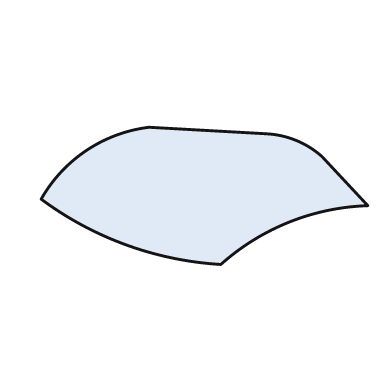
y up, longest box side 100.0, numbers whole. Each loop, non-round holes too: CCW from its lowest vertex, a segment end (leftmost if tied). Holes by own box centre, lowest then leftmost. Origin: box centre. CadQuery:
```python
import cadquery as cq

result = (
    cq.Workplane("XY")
    .moveTo(5.0, -21.0)
    .threePointArc((26.0, -8.0), (50.0, -3.0))
    .lineTo(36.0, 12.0)
    .threePointArc((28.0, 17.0), (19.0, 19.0))
    .lineTo(-17.0, 21.0)
    .threePointArc((-36.0, 14.0), (-50.0, -1.0))
    .threePointArc((-24.0, -15.0), (5.0, -21.0))
    .close()
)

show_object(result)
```